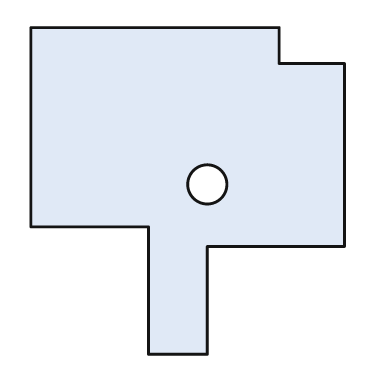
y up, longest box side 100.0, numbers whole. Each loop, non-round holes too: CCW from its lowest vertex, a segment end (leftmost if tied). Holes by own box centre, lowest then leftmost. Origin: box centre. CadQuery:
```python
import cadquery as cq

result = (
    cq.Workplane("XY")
    .moveTo(-12.0, -50.0)
    .lineTo(6.0, -50.0)
    .lineTo(6.0, -17.0)
    .lineTo(48.0, -17.0)
    .lineTo(48.0, 39.0)
    .lineTo(28.0, 39.0)
    .lineTo(28.0, 50.0)
    .lineTo(-48.0, 50.0)
    .lineTo(-48.0, -11.0)
    .lineTo(-12.0, -11.0)
    .close()
    .moveTo(6.0, 2.0)
    .circle(6.0)
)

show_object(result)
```